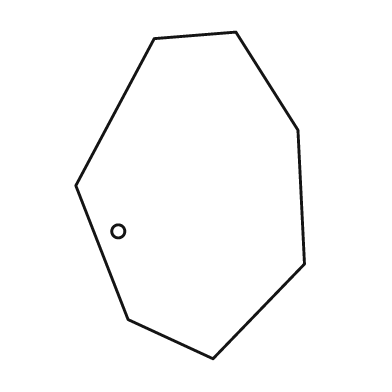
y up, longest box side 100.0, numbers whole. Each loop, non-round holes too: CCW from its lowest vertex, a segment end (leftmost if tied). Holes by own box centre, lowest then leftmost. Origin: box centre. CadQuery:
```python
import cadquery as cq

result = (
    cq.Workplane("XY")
    .moveTo(7.0, -50.0)
    .lineTo(35.0, -21.0)
    .lineTo(33.0, 20.0)
    .lineTo(14.0, 50.0)
    .lineTo(-11.0, 48.0)
    .lineTo(-35.0, 3.0)
    .lineTo(-19.0, -38.0)
    .close()
    .moveTo(-22.0, -11.0)
    .circle(2.0)
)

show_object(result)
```